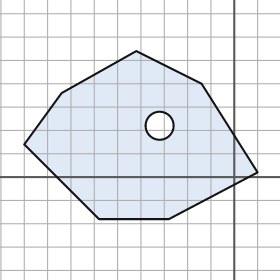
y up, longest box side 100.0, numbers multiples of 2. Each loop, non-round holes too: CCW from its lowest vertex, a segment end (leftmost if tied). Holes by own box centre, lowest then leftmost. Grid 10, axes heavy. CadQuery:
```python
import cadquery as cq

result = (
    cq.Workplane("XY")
    .moveTo(-58.0, -18.0)
    .lineTo(-28.0, -18.0)
    .lineTo(10.0, 2.0)
    .lineTo(-14.0, 40.0)
    .lineTo(-42.0, 54.0)
    .lineTo(-74.0, 36.0)
    .lineTo(-90.0, 14.0)
    .close()
    .moveTo(-32.0, 22.0)
    .circle(6.0)
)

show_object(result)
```